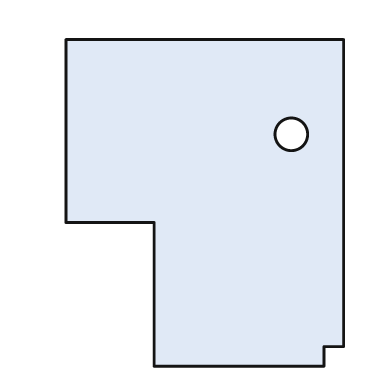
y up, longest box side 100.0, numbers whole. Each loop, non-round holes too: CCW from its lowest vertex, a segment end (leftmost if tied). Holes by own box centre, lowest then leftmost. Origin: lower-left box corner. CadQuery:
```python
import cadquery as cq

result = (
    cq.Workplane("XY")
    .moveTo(27.0, 0.0)
    .lineTo(79.0, 0.0)
    .lineTo(79.0, 6.0)
    .lineTo(85.0, 6.0)
    .lineTo(85.0, 100.0)
    .lineTo(0.0, 100.0)
    .lineTo(0.0, 44.0)
    .lineTo(27.0, 44.0)
    .close()
    .moveTo(69.0, 71.0)
    .circle(5.0)
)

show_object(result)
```